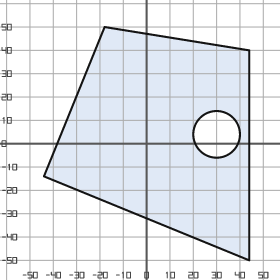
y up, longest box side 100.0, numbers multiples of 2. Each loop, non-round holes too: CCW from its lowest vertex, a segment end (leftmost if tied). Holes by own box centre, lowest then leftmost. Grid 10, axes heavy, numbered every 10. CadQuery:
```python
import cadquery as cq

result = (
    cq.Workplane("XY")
    .moveTo(44.0, -50.0)
    .lineTo(44.0, 40.0)
    .lineTo(-18.0, 50.0)
    .lineTo(-44.0, -14.0)
    .close()
    .moveTo(30.0, 4.0)
    .circle(10.0)
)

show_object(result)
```